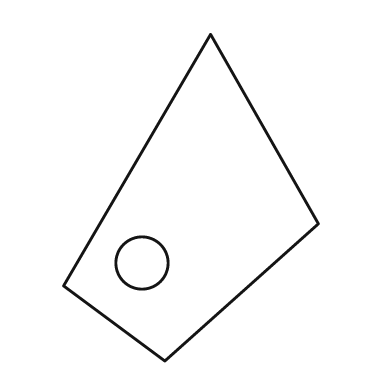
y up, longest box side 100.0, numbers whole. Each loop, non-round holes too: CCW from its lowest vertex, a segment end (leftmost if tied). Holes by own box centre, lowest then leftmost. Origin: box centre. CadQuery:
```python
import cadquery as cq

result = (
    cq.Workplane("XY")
    .moveTo(-8.0, -50.0)
    .lineTo(39.0, -8.0)
    .lineTo(6.0, 50.0)
    .lineTo(-39.0, -27.0)
    .close()
    .moveTo(-15.0, -20.0)
    .circle(8.0)
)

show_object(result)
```